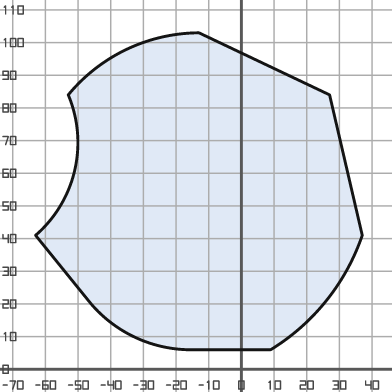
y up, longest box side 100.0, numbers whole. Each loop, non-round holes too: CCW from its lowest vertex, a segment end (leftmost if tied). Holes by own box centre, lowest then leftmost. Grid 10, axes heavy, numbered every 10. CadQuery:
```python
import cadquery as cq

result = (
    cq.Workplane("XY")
    .moveTo(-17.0, 6.0)
    .lineTo(9.0, 6.0)
    .threePointArc((26.0, 21.0), (37.0, 41.0))
    .lineTo(27.0, 84.0)
    .lineTo(-13.0, 103.0)
    .threePointArc((-35.0, 98.0), (-53.0, 84.0))
    .threePointArc((-51.0, 61.0), (-63.0, 41.0))
    .lineTo(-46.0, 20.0)
    .threePointArc((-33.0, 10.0), (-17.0, 6.0))
    .close()
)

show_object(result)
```